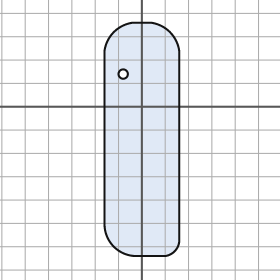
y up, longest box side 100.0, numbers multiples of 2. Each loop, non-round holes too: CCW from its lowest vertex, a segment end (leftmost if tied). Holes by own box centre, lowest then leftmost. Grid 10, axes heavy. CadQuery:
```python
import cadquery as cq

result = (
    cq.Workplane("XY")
    .moveTo(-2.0, -64.0)
    .lineTo(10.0, -64.0)
    .threePointArc((14.0, -62.0), (16.0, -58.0))
    .lineTo(16.0, 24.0)
    .threePointArc((12.0, 32.0), (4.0, 36.0))
    .lineTo(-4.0, 36.0)
    .threePointArc((-12.0, 32.0), (-16.0, 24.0))
    .lineTo(-16.0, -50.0)
    .threePointArc((-12.0, -60.0), (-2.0, -64.0))
    .close()
    .moveTo(-8.0, 14.0)
    .circle(2.0)
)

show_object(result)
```